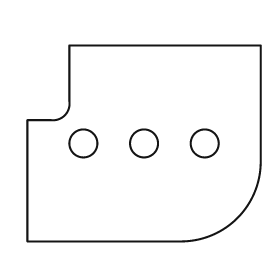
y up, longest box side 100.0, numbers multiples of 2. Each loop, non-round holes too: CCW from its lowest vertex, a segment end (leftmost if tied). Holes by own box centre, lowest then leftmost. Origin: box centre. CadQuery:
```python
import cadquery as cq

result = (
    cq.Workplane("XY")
    .moveTo(-50.0, -42.0)
    .lineTo(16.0, -42.0)
    .threePointArc((40.0, -32.0), (50.0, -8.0))
    .lineTo(50.0, 42.0)
    .lineTo(-32.0, 42.0)
    .lineTo(-32.0, 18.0)
    .threePointArc((-34.0, 12.0), (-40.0, 10.0))
    .lineTo(-50.0, 10.0)
    .close()
    .moveTo(-26.0, 0.0)
    .circle(6.0)
    .moveTo(0.0, 0.0)
    .circle(6.0)
    .moveTo(26.0, 0.0)
    .circle(6.0)
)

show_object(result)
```